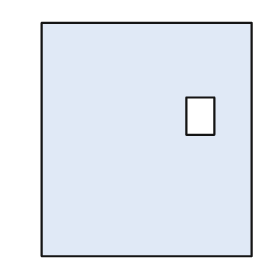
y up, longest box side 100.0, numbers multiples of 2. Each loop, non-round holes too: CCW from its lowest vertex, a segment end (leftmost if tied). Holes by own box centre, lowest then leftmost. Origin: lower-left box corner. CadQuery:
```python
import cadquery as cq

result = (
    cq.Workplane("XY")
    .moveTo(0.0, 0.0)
    .lineTo(90.0, 0.0)
    .lineTo(90.0, 100.0)
    .lineTo(0.0, 100.0)
    .close()
    .moveTo(62.0, 52.0)
    .lineTo(74.0, 52.0)
    .lineTo(74.0, 68.0)
    .lineTo(62.0, 68.0)
    .close()
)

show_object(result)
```